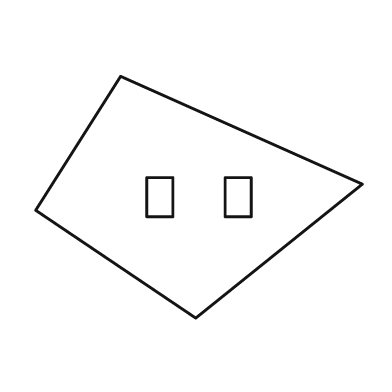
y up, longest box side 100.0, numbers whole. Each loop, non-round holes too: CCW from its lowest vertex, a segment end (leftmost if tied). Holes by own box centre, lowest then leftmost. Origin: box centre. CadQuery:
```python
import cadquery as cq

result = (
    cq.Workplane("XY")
    .moveTo(-1.0, -37.0)
    .lineTo(50.0, 4.0)
    .lineTo(-24.0, 37.0)
    .lineTo(-50.0, -4.0)
    .close()
    .moveTo(-16.0, -6.0)
    .lineTo(-8.0, -6.0)
    .lineTo(-8.0, 6.0)
    .lineTo(-16.0, 6.0)
    .close()
    .moveTo(8.0, -6.0)
    .lineTo(16.0, -6.0)
    .lineTo(16.0, 6.0)
    .lineTo(8.0, 6.0)
    .close()
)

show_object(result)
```